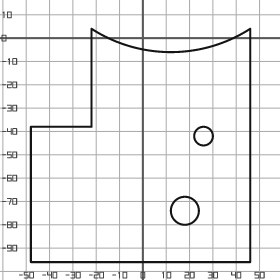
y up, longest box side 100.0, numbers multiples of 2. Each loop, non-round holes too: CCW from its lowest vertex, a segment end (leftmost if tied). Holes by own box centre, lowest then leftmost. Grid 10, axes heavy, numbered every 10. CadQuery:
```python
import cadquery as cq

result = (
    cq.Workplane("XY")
    .moveTo(-48.0, -96.0)
    .lineTo(46.0, -96.0)
    .lineTo(46.0, 4.0)
    .threePointArc((12.0, -6.0), (-22.0, 4.0))
    .lineTo(-22.0, -38.0)
    .lineTo(-48.0, -38.0)
    .close()
    .moveTo(18.0, -74.0)
    .circle(6.0)
    .moveTo(26.0, -42.0)
    .circle(4.0)
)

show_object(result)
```